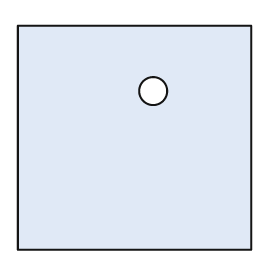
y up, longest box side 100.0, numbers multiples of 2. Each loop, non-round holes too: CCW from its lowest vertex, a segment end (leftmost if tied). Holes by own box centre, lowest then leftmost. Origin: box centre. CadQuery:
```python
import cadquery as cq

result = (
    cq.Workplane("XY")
    .moveTo(-50.0, -48.0)
    .lineTo(50.0, -48.0)
    .lineTo(50.0, 48.0)
    .lineTo(-50.0, 48.0)
    .close()
    .moveTo(8.0, 20.0)
    .circle(6.0)
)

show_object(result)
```